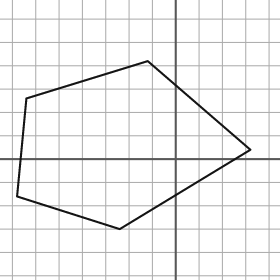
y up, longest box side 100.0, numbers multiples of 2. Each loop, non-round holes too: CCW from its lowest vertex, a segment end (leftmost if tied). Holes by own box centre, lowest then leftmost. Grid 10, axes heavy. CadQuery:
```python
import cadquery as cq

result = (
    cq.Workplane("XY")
    .moveTo(-24.0, -30.0)
    .lineTo(32.0, 4.0)
    .lineTo(-12.0, 42.0)
    .lineTo(-64.0, 26.0)
    .lineTo(-68.0, -16.0)
    .close()
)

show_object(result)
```